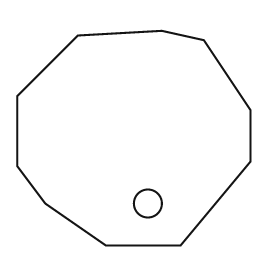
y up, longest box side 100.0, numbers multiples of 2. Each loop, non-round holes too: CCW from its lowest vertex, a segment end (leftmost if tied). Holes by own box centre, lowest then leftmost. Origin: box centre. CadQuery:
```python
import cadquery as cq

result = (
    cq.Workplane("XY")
    .moveTo(-12.0, -46.0)
    .lineTo(20.0, -46.0)
    .lineTo(50.0, -10.0)
    .lineTo(50.0, 12.0)
    .lineTo(30.0, 42.0)
    .lineTo(12.0, 46.0)
    .lineTo(-24.0, 44.0)
    .lineTo(-50.0, 18.0)
    .lineTo(-50.0, -12.0)
    .lineTo(-38.0, -28.0)
    .close()
    .moveTo(6.0, -28.0)
    .circle(6.0)
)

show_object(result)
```